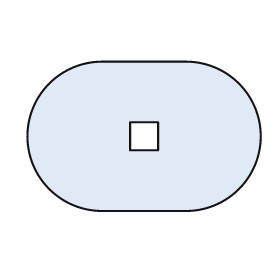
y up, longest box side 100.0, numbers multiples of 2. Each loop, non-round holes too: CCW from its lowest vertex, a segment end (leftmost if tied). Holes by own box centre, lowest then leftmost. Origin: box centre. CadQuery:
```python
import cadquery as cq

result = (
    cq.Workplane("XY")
    .moveTo(-18.0, -32.0)
    .lineTo(18.0, -32.0)
    .threePointArc((50.0, 0.0), (18.0, 32.0))
    .lineTo(-18.0, 32.0)
    .threePointArc((-50.0, 0.0), (-18.0, -32.0))
    .close()
    .moveTo(-6.0, -6.0)
    .lineTo(6.0, -6.0)
    .lineTo(6.0, 6.0)
    .lineTo(-6.0, 6.0)
    .close()
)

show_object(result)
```